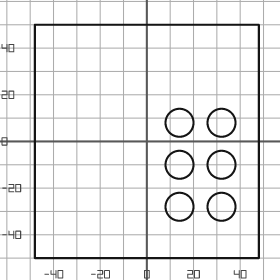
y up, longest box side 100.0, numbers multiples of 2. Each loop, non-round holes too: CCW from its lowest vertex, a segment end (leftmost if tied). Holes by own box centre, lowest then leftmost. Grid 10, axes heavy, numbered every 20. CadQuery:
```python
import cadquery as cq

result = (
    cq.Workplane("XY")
    .moveTo(-48.0, -50.0)
    .lineTo(48.0, -50.0)
    .lineTo(48.0, 50.0)
    .lineTo(-48.0, 50.0)
    .close()
    .moveTo(14.0, -28.0)
    .circle(6.0)
    .moveTo(32.0, -28.0)
    .circle(6.0)
    .moveTo(14.0, -10.0)
    .circle(6.0)
    .moveTo(32.0, -10.0)
    .circle(6.0)
    .moveTo(14.0, 8.0)
    .circle(6.0)
    .moveTo(32.0, 8.0)
    .circle(6.0)
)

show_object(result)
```